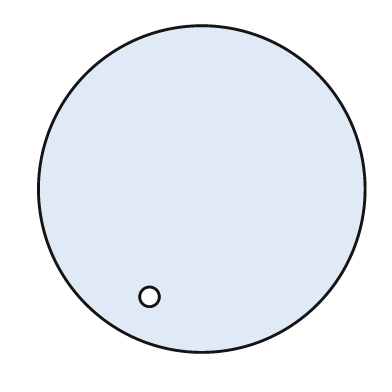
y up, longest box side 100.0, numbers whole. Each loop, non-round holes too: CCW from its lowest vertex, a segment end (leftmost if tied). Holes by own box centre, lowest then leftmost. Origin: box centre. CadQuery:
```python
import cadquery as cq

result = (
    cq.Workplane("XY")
    .moveTo(0.0, 0.0)
    .circle(50.0)
    .moveTo(-16.0, -33.0)
    .circle(3.0)
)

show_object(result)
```